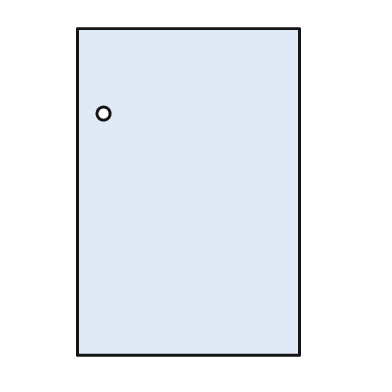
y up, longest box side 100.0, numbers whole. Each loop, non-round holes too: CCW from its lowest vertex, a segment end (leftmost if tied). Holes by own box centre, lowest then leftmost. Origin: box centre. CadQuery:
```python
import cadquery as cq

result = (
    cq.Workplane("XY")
    .moveTo(-34.0, -50.0)
    .lineTo(34.0, -50.0)
    .lineTo(34.0, 50.0)
    .lineTo(-34.0, 50.0)
    .close()
    .moveTo(-26.0, 24.0)
    .circle(2.0)
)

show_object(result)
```